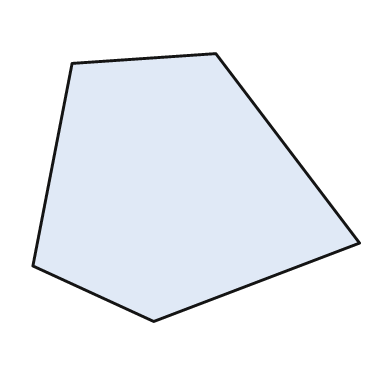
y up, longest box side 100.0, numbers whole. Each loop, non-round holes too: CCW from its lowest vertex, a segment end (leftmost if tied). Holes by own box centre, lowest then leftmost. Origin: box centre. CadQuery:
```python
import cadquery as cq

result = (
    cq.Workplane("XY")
    .moveTo(-13.0, -41.0)
    .lineTo(50.0, -17.0)
    .lineTo(6.0, 41.0)
    .lineTo(-38.0, 38.0)
    .lineTo(-50.0, -24.0)
    .close()
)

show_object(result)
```